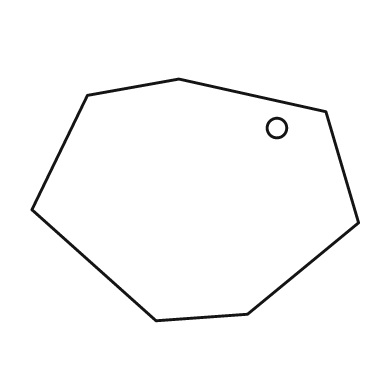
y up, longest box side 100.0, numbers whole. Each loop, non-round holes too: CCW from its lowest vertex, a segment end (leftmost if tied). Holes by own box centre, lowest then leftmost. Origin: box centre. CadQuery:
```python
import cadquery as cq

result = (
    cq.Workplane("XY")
    .moveTo(-12.0, -37.0)
    .lineTo(16.0, -35.0)
    .lineTo(50.0, -7.0)
    .lineTo(40.0, 27.0)
    .lineTo(-5.0, 37.0)
    .lineTo(-33.0, 32.0)
    .lineTo(-50.0, -3.0)
    .close()
    .moveTo(25.0, 22.0)
    .circle(3.0)
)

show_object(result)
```